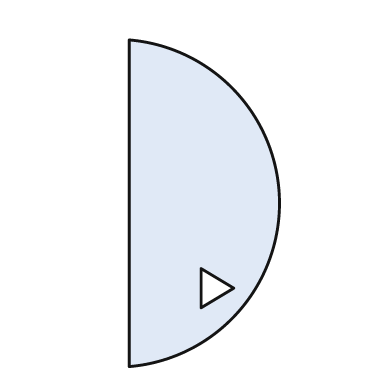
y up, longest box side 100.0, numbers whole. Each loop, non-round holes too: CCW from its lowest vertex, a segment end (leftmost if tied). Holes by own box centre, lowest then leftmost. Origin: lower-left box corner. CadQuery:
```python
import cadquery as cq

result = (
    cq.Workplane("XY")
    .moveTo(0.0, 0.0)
    .threePointArc((46.0, 50.0), (0.0, 100.0))
    .close()
    .moveTo(22.0, 18.0)
    .lineTo(32.0, 24.0)
    .lineTo(22.0, 30.0)
    .close()
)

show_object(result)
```